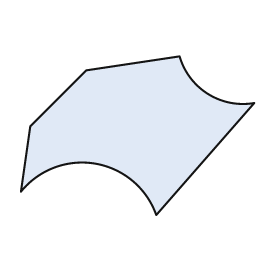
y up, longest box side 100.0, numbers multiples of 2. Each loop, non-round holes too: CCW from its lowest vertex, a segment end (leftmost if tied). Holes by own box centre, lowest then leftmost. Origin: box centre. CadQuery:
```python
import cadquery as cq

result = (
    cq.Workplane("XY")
    .moveTo(8.0, -34.0)
    .lineTo(50.0, 14.0)
    .threePointArc((30.0, 18.0), (18.0, 34.0))
    .lineTo(-22.0, 28.0)
    .lineTo(-46.0, 4.0)
    .lineTo(-50.0, -24.0)
    .threePointArc((-18.0, -12.0), (8.0, -34.0))
    .close()
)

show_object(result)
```